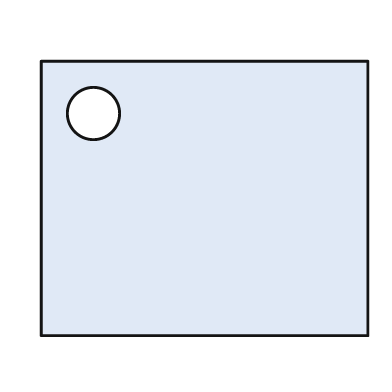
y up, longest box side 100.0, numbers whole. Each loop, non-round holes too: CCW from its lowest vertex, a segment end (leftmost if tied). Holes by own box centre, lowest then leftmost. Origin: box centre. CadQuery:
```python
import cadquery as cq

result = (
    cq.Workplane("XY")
    .moveTo(-50.0, -42.0)
    .lineTo(50.0, -42.0)
    .lineTo(50.0, 42.0)
    .lineTo(-50.0, 42.0)
    .close()
    .moveTo(-34.0, 26.0)
    .circle(8.0)
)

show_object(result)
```